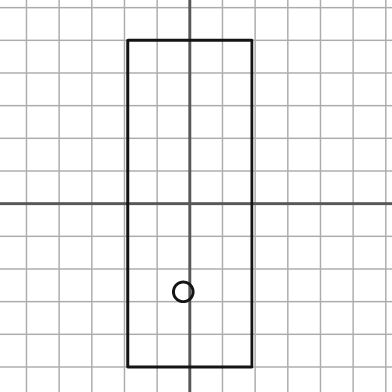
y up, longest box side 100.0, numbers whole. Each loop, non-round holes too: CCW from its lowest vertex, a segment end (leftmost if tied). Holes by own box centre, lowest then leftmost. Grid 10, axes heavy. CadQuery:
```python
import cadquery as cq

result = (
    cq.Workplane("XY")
    .moveTo(-19.0, -50.0)
    .lineTo(19.0, -50.0)
    .lineTo(19.0, 50.0)
    .lineTo(-19.0, 50.0)
    .close()
    .moveTo(-2.0, -27.0)
    .circle(3.0)
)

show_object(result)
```